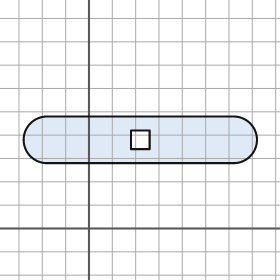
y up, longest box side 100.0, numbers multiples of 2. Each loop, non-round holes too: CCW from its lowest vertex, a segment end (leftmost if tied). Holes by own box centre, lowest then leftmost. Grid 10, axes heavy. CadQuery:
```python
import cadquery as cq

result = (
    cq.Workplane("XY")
    .moveTo(-18.0, 28.0)
    .lineTo(62.0, 28.0)
    .threePointArc((72.0, 38.0), (62.0, 48.0))
    .lineTo(-18.0, 48.0)
    .threePointArc((-28.0, 38.0), (-18.0, 28.0))
    .close()
    .moveTo(18.0, 34.0)
    .lineTo(26.0, 34.0)
    .lineTo(26.0, 42.0)
    .lineTo(18.0, 42.0)
    .close()
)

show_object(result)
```